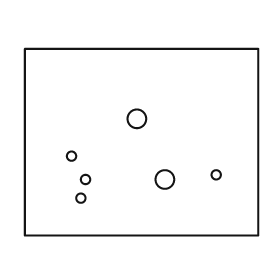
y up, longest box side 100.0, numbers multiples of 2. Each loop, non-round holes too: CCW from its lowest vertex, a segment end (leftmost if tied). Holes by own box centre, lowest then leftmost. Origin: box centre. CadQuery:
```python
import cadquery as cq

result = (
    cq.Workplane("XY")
    .moveTo(-50.0, -40.0)
    .lineTo(50.0, -40.0)
    .lineTo(50.0, 40.0)
    .lineTo(-50.0, 40.0)
    .close()
    .moveTo(-26.0, -24.0)
    .circle(2.0)
    .moveTo(-24.0, -16.0)
    .circle(2.0)
    .moveTo(10.0, -16.0)
    .circle(4.0)
    .moveTo(32.0, -14.0)
    .circle(2.0)
    .moveTo(-30.0, -6.0)
    .circle(2.0)
    .moveTo(-2.0, 10.0)
    .circle(4.0)
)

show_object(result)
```